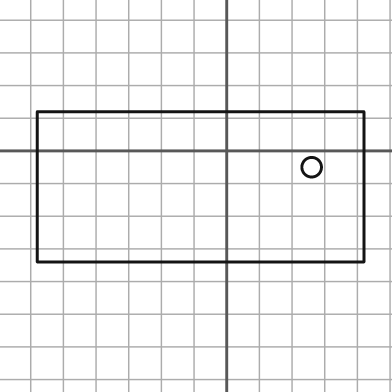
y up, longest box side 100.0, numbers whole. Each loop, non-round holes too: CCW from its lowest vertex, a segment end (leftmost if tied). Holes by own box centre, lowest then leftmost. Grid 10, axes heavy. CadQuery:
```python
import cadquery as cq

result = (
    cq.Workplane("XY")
    .moveTo(-58.0, -34.0)
    .lineTo(42.0, -34.0)
    .lineTo(42.0, 12.0)
    .lineTo(-58.0, 12.0)
    .close()
    .moveTo(26.0, -5.0)
    .circle(3.0)
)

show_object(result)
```